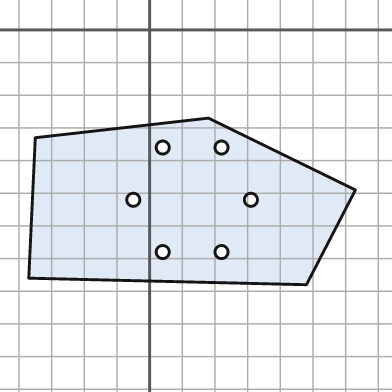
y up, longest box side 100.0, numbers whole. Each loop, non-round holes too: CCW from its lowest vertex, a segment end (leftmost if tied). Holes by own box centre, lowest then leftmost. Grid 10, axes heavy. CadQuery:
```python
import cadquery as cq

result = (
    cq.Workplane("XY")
    .moveTo(48.0, -78.0)
    .lineTo(63.0, -49.0)
    .lineTo(18.0, -27.0)
    .lineTo(-35.0, -33.0)
    .lineTo(-37.0, -76.0)
    .close()
    .moveTo(4.0, -68.0)
    .circle(2.0)
    .moveTo(22.0, -68.0)
    .circle(2.0)
    .moveTo(-5.0, -52.0)
    .circle(2.0)
    .moveTo(31.0, -52.0)
    .circle(2.0)
    .moveTo(4.0, -36.0)
    .circle(2.0)
    .moveTo(22.0, -36.0)
    .circle(2.0)
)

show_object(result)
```